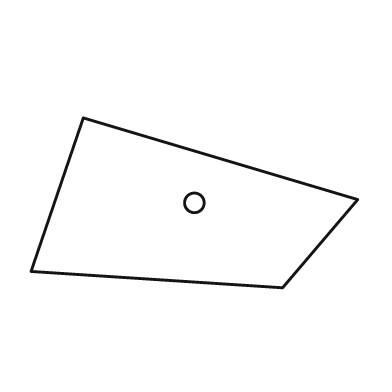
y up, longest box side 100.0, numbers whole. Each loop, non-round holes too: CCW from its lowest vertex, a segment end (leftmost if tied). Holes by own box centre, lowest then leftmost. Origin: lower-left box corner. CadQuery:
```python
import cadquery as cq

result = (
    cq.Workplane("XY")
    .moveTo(77.0, 0.0)
    .lineTo(100.0, 27.0)
    .lineTo(16.0, 52.0)
    .lineTo(0.0, 5.0)
    .close()
    .moveTo(50.0, 26.0)
    .circle(3.0)
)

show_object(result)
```